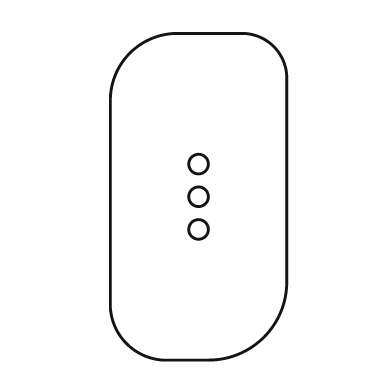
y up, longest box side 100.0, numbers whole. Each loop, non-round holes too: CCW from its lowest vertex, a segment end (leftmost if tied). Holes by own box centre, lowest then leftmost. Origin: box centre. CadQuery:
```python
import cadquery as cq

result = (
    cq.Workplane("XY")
    .moveTo(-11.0, -50.0)
    .lineTo(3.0, -50.0)
    .threePointArc((20.0, -43.0), (27.0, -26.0))
    .lineTo(27.0, 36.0)
    .threePointArc((23.0, 46.0), (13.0, 50.0))
    .lineTo(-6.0, 50.0)
    .threePointArc((-21.0, 44.0), (-27.0, 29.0))
    .lineTo(-27.0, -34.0)
    .threePointArc((-22.0, -45.0), (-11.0, -50.0))
    .close()
    .moveTo(0.0, -10.0)
    .circle(3.0)
    .moveTo(0.0, 0.0)
    .circle(3.0)
    .moveTo(0.0, 10.0)
    .circle(3.0)
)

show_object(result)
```